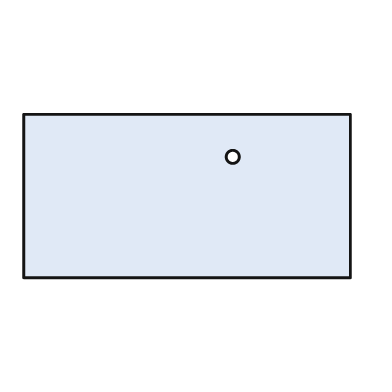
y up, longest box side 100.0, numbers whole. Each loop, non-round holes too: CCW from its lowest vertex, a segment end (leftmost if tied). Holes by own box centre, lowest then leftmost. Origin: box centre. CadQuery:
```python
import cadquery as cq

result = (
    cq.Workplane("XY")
    .moveTo(-50.0, -25.0)
    .lineTo(50.0, -25.0)
    .lineTo(50.0, 25.0)
    .lineTo(-50.0, 25.0)
    .close()
    .moveTo(14.0, 12.0)
    .circle(2.0)
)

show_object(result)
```